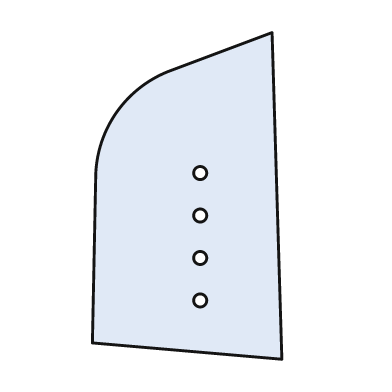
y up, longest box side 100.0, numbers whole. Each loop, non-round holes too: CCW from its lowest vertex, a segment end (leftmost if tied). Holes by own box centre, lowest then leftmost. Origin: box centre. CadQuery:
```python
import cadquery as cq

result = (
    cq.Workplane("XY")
    .moveTo(29.0, -50.0)
    .lineTo(26.0, 50.0)
    .lineTo(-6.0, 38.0)
    .threePointArc((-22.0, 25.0), (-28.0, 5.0))
    .lineTo(-29.0, -45.0)
    .close()
    .moveTo(4.0, -32.0)
    .circle(2.0)
    .moveTo(4.0, -19.0)
    .circle(2.0)
    .moveTo(4.0, -6.0)
    .circle(2.0)
    .moveTo(4.0, 7.0)
    .circle(2.0)
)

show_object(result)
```